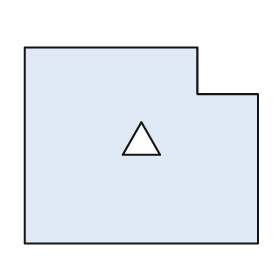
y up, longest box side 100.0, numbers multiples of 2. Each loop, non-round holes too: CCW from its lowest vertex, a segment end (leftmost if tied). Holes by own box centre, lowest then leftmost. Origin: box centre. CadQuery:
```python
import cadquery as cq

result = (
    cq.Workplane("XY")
    .moveTo(-50.0, -42.0)
    .lineTo(50.0, -42.0)
    .lineTo(50.0, 22.0)
    .lineTo(24.0, 22.0)
    .lineTo(24.0, 42.0)
    .lineTo(-50.0, 42.0)
    .close()
    .moveTo(-8.0, -4.0)
    .lineTo(8.0, -4.0)
    .lineTo(0.0, 10.0)
    .close()
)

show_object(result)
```